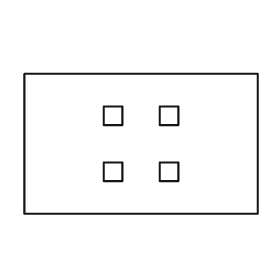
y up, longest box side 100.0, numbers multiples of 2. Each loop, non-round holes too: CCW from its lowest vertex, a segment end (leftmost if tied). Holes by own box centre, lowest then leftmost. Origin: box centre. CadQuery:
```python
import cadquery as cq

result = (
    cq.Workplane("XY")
    .moveTo(-50.0, -30.0)
    .lineTo(50.0, -30.0)
    .lineTo(50.0, 30.0)
    .lineTo(-50.0, 30.0)
    .close()
    .moveTo(-16.0, -16.0)
    .lineTo(-8.0, -16.0)
    .lineTo(-8.0, -8.0)
    .lineTo(-16.0, -8.0)
    .close()
    .moveTo(8.0, -16.0)
    .lineTo(16.0, -16.0)
    .lineTo(16.0, -8.0)
    .lineTo(8.0, -8.0)
    .close()
    .moveTo(-16.0, 8.0)
    .lineTo(-8.0, 8.0)
    .lineTo(-8.0, 16.0)
    .lineTo(-16.0, 16.0)
    .close()
    .moveTo(8.0, 8.0)
    .lineTo(16.0, 8.0)
    .lineTo(16.0, 16.0)
    .lineTo(8.0, 16.0)
    .close()
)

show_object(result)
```